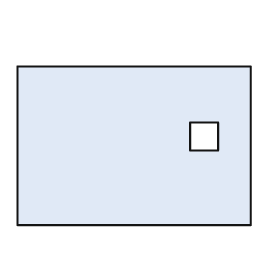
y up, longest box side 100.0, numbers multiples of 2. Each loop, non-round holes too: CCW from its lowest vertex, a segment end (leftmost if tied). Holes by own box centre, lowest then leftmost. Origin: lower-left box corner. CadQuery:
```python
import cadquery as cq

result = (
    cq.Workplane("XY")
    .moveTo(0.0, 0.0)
    .lineTo(100.0, 0.0)
    .lineTo(100.0, 68.0)
    .lineTo(0.0, 68.0)
    .close()
    .moveTo(74.0, 32.0)
    .lineTo(86.0, 32.0)
    .lineTo(86.0, 44.0)
    .lineTo(74.0, 44.0)
    .close()
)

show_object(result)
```